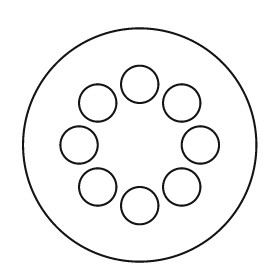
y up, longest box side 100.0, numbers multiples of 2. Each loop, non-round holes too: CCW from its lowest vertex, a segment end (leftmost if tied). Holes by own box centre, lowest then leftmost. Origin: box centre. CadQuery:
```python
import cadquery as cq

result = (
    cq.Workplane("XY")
    .moveTo(0.0, 0.0)
    .circle(50.0)
    .moveTo(0.0, -26.0)
    .circle(8.0)
    .moveTo(-18.0, -18.0)
    .circle(8.0)
    .moveTo(18.0, -18.0)
    .circle(8.0)
    .moveTo(-26.0, 0.0)
    .circle(8.0)
    .moveTo(26.0, 0.0)
    .circle(8.0)
    .moveTo(-18.0, 18.0)
    .circle(8.0)
    .moveTo(18.0, 18.0)
    .circle(8.0)
    .moveTo(0.0, 26.0)
    .circle(8.0)
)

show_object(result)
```